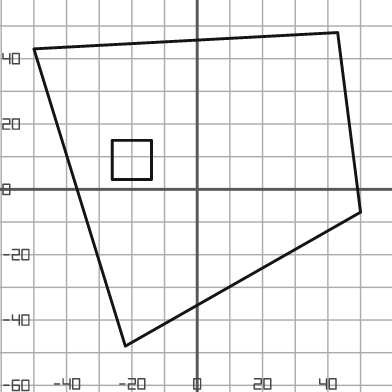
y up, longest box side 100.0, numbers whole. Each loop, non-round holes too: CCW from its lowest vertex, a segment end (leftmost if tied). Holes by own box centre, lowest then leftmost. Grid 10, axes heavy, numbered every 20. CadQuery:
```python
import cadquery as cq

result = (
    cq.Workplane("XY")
    .moveTo(-22.0, -48.0)
    .lineTo(50.0, -7.0)
    .lineTo(43.0, 48.0)
    .lineTo(-50.0, 43.0)
    .close()
    .moveTo(-26.0, 3.0)
    .lineTo(-14.0, 3.0)
    .lineTo(-14.0, 15.0)
    .lineTo(-26.0, 15.0)
    .close()
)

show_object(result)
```